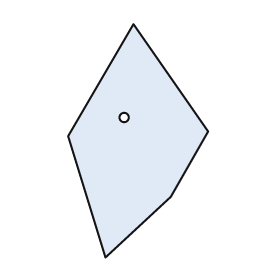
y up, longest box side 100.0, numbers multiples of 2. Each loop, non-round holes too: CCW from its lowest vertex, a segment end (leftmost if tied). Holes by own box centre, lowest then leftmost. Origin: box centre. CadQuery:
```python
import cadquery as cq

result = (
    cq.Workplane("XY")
    .moveTo(-14.0, -50.0)
    .lineTo(14.0, -24.0)
    .lineTo(30.0, 4.0)
    .lineTo(-2.0, 50.0)
    .lineTo(-30.0, 2.0)
    .close()
    .moveTo(-6.0, 10.0)
    .circle(2.0)
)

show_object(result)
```